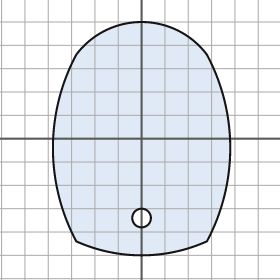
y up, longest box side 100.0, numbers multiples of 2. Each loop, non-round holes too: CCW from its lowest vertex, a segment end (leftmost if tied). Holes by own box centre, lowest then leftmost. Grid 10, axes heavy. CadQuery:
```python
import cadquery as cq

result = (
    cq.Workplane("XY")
    .moveTo(-28.0, -44.0)
    .threePointArc((0.0, -50.0), (28.0, -44.0))
    .threePointArc((38.0, -4.0), (28.0, 36.0))
    .threePointArc((0.0, 50.0), (-28.0, 36.0))
    .threePointArc((-38.0, -4.0), (-28.0, -44.0))
    .close()
    .moveTo(0.0, -34.0)
    .circle(4.0)
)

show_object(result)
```